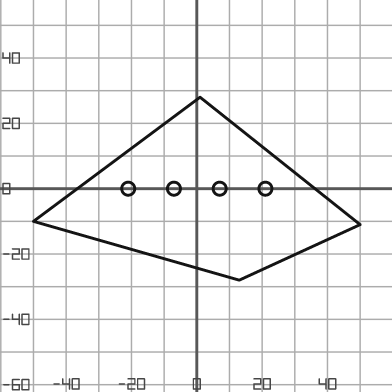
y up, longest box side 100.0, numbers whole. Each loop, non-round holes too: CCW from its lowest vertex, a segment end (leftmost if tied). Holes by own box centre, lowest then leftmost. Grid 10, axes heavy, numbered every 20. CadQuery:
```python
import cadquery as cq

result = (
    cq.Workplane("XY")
    .moveTo(13.0, -28.0)
    .lineTo(50.0, -11.0)
    .lineTo(1.0, 28.0)
    .lineTo(-50.0, -10.0)
    .close()
    .moveTo(-21.0, 0.0)
    .circle(2.0)
    .moveTo(-7.0, 0.0)
    .circle(2.0)
    .moveTo(7.0, 0.0)
    .circle(2.0)
    .moveTo(21.0, 0.0)
    .circle(2.0)
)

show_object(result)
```